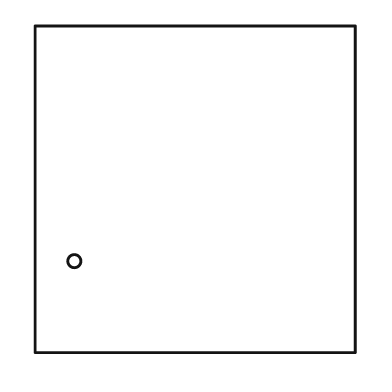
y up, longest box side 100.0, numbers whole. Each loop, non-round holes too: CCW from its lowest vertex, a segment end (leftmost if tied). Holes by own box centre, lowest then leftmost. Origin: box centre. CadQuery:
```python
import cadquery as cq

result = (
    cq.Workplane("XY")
    .moveTo(-49.0, -50.0)
    .lineTo(49.0, -50.0)
    .lineTo(49.0, 50.0)
    .lineTo(-49.0, 50.0)
    .close()
    .moveTo(-37.0, -22.0)
    .circle(2.0)
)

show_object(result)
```